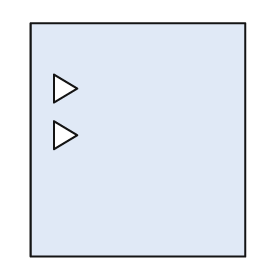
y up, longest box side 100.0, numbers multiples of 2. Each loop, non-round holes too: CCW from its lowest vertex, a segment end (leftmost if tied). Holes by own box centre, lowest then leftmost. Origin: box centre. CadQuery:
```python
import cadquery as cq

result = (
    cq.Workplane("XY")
    .moveTo(-46.0, -50.0)
    .lineTo(46.0, -50.0)
    .lineTo(46.0, 50.0)
    .lineTo(-46.0, 50.0)
    .close()
    .moveTo(-36.0, -4.0)
    .lineTo(-26.0, 2.0)
    .lineTo(-36.0, 8.0)
    .close()
    .moveTo(-36.0, 16.0)
    .lineTo(-26.0, 22.0)
    .lineTo(-36.0, 28.0)
    .close()
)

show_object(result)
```